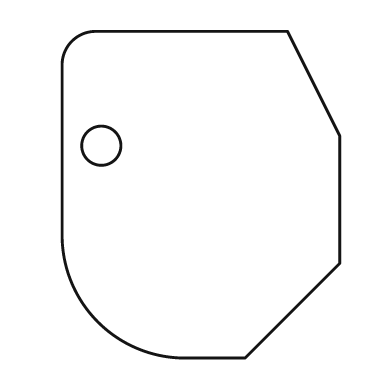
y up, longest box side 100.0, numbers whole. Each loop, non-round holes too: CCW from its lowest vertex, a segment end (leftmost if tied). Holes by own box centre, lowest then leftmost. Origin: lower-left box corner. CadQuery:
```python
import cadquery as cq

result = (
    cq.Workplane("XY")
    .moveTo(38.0, 0.0)
    .lineTo(56.0, 0.0)
    .lineTo(85.0, 29.0)
    .lineTo(85.0, 68.0)
    .lineTo(69.0, 100.0)
    .lineTo(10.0, 100.0)
    .threePointArc((3.0, 97.0), (0.0, 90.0))
    .lineTo(0.0, 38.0)
    .threePointArc((11.0, 11.0), (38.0, 0.0))
    .close()
    .moveTo(12.0, 65.0)
    .circle(6.0)
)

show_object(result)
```